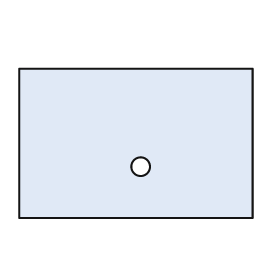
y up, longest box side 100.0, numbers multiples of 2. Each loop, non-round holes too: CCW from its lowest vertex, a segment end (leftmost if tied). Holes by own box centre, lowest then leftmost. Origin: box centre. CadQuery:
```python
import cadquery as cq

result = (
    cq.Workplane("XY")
    .moveTo(-50.0, -32.0)
    .lineTo(50.0, -32.0)
    .lineTo(50.0, 32.0)
    .lineTo(-50.0, 32.0)
    .close()
    .moveTo(2.0, -10.0)
    .circle(4.0)
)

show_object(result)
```